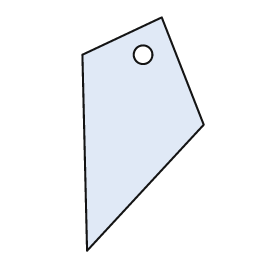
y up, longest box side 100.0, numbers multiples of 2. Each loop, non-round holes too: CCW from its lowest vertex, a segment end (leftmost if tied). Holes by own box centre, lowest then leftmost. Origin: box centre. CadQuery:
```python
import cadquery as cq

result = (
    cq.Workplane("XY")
    .moveTo(-24.0, -50.0)
    .lineTo(26.0, 4.0)
    .lineTo(8.0, 50.0)
    .lineTo(-26.0, 34.0)
    .close()
    .moveTo(0.0, 34.0)
    .circle(4.0)
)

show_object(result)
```